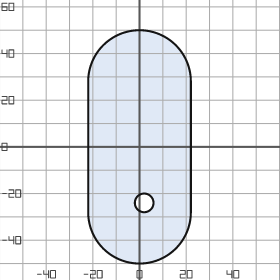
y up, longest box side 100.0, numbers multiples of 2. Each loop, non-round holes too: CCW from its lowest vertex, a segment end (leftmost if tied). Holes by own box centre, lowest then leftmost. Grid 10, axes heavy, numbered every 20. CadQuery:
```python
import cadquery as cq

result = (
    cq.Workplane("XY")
    .moveTo(-22.0, -28.0)
    .threePointArc((0.0, -50.0), (22.0, -28.0))
    .lineTo(22.0, 28.0)
    .threePointArc((0.0, 50.0), (-22.0, 28.0))
    .close()
    .moveTo(2.0, -24.0)
    .circle(4.0)
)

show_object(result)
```